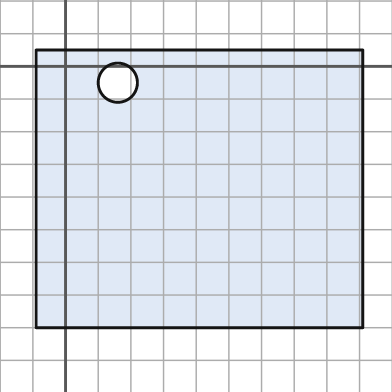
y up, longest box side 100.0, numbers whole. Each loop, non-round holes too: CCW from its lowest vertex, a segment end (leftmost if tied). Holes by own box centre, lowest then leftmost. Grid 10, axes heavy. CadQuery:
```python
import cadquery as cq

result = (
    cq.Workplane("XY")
    .moveTo(-9.0, -80.0)
    .lineTo(91.0, -80.0)
    .lineTo(91.0, 5.0)
    .lineTo(-9.0, 5.0)
    .close()
    .moveTo(16.0, -5.0)
    .circle(6.0)
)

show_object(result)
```